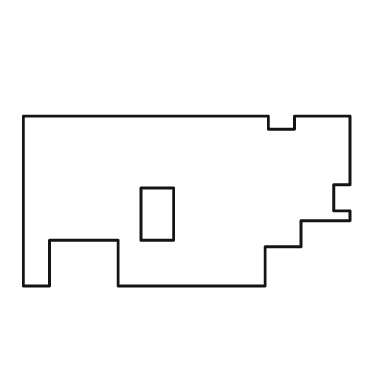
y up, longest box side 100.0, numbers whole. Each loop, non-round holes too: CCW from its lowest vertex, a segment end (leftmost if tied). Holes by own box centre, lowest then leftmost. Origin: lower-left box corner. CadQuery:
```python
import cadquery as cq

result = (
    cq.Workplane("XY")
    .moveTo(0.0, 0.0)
    .lineTo(8.0, 0.0)
    .lineTo(8.0, 14.0)
    .lineTo(29.0, 14.0)
    .lineTo(29.0, 0.0)
    .lineTo(74.0, 0.0)
    .lineTo(74.0, 12.0)
    .lineTo(85.0, 12.0)
    .lineTo(85.0, 20.0)
    .lineTo(100.0, 20.0)
    .lineTo(100.0, 23.0)
    .lineTo(95.0, 23.0)
    .lineTo(95.0, 31.0)
    .lineTo(100.0, 31.0)
    .lineTo(100.0, 52.0)
    .lineTo(83.0, 52.0)
    .lineTo(83.0, 48.0)
    .lineTo(75.0, 48.0)
    .lineTo(75.0, 52.0)
    .lineTo(0.0, 52.0)
    .close()
    .moveTo(36.0, 14.0)
    .lineTo(46.0, 14.0)
    .lineTo(46.0, 30.0)
    .lineTo(36.0, 30.0)
    .close()
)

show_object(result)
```